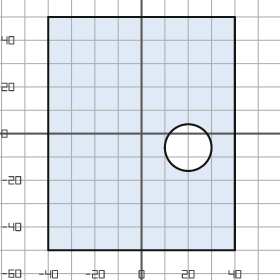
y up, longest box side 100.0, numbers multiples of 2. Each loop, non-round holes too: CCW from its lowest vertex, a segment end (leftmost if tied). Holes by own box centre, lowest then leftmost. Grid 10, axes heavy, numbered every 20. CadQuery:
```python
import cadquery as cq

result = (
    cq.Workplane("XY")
    .moveTo(-40.0, -50.0)
    .lineTo(40.0, -50.0)
    .lineTo(40.0, 50.0)
    .lineTo(-40.0, 50.0)
    .close()
    .moveTo(20.0, -6.0)
    .circle(10.0)
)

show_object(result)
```